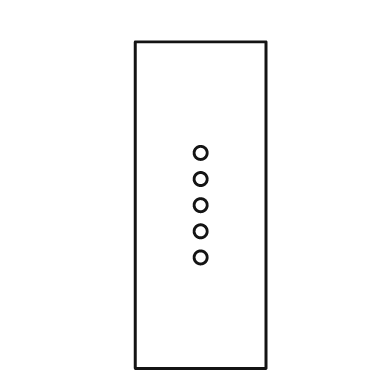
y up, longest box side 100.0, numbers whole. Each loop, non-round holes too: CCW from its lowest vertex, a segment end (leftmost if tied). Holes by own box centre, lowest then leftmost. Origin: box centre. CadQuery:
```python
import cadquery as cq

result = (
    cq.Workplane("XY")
    .moveTo(-20.0, -50.0)
    .lineTo(20.0, -50.0)
    .lineTo(20.0, 50.0)
    .lineTo(-20.0, 50.0)
    .close()
    .moveTo(0.0, -16.0)
    .circle(2.0)
    .moveTo(0.0, -8.0)
    .circle(2.0)
    .moveTo(0.0, 0.0)
    .circle(2.0)
    .moveTo(0.0, 8.0)
    .circle(2.0)
    .moveTo(0.0, 16.0)
    .circle(2.0)
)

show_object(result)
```